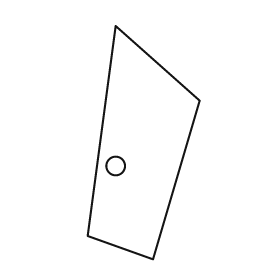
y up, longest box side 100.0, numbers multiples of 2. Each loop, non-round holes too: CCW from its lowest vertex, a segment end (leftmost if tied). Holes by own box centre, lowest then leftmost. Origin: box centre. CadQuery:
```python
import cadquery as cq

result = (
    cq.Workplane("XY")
    .moveTo(4.0, -50.0)
    .lineTo(24.0, 18.0)
    .lineTo(-12.0, 50.0)
    .lineTo(-24.0, -40.0)
    .close()
    .moveTo(-12.0, -10.0)
    .circle(4.0)
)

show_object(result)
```